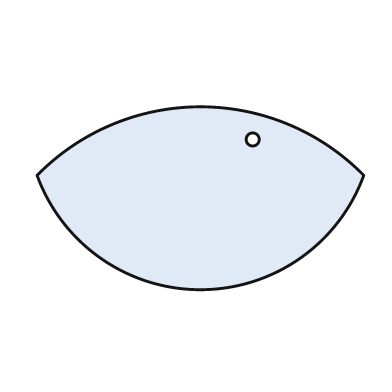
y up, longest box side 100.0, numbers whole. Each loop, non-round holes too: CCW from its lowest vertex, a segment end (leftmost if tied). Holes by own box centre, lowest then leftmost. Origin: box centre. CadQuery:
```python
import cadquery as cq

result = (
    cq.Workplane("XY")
    .moveTo(-50.0, 7.0)
    .threePointArc((0.0, -28.0), (50.0, 7.0))
    .threePointArc((0.0, 28.0), (-50.0, 7.0))
    .close()
    .moveTo(16.0, 18.0)
    .circle(2.0)
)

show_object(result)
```